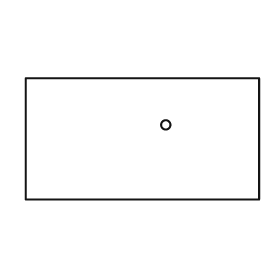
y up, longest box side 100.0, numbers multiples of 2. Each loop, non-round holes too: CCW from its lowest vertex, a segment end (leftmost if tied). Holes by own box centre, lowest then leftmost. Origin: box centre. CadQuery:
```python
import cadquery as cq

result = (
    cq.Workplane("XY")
    .moveTo(-50.0, -26.0)
    .lineTo(50.0, -26.0)
    .lineTo(50.0, 26.0)
    .lineTo(-50.0, 26.0)
    .close()
    .moveTo(10.0, 6.0)
    .circle(2.0)
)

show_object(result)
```